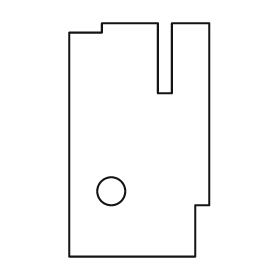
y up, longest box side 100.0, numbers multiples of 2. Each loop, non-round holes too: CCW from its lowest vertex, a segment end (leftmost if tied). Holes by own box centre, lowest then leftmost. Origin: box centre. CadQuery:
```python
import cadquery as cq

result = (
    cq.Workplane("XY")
    .moveTo(-30.0, -50.0)
    .lineTo(24.0, -50.0)
    .lineTo(24.0, -28.0)
    .lineTo(30.0, -28.0)
    .lineTo(30.0, 50.0)
    .lineTo(14.0, 50.0)
    .lineTo(14.0, 20.0)
    .lineTo(8.0, 20.0)
    .lineTo(8.0, 50.0)
    .lineTo(-16.0, 50.0)
    .lineTo(-16.0, 46.0)
    .lineTo(-30.0, 46.0)
    .close()
    .moveTo(-12.0, -22.0)
    .circle(6.0)
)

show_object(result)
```